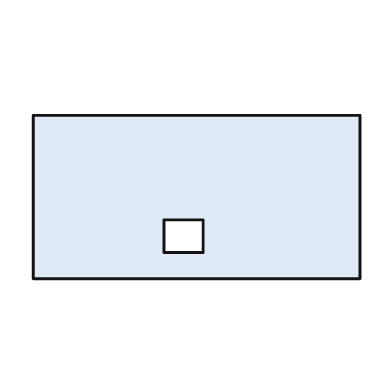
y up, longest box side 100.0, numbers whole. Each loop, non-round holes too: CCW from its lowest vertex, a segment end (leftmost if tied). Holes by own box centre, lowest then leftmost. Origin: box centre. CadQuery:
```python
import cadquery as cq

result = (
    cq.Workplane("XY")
    .moveTo(-50.0, -25.0)
    .lineTo(50.0, -25.0)
    .lineTo(50.0, 25.0)
    .lineTo(-50.0, 25.0)
    .close()
    .moveTo(-10.0, -17.0)
    .lineTo(2.0, -17.0)
    .lineTo(2.0, -7.0)
    .lineTo(-10.0, -7.0)
    .close()
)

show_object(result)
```